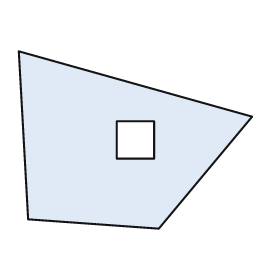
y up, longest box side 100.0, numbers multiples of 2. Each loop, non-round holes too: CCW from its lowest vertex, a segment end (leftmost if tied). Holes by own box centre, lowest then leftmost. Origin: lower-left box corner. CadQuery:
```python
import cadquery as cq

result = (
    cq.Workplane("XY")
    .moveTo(60.0, 0.0)
    .lineTo(100.0, 48.0)
    .lineTo(0.0, 76.0)
    .lineTo(4.0, 4.0)
    .close()
    .moveTo(42.0, 30.0)
    .lineTo(58.0, 30.0)
    .lineTo(58.0, 46.0)
    .lineTo(42.0, 46.0)
    .close()
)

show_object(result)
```